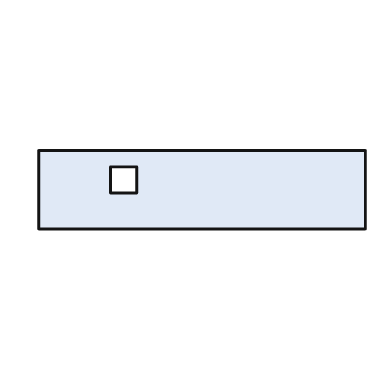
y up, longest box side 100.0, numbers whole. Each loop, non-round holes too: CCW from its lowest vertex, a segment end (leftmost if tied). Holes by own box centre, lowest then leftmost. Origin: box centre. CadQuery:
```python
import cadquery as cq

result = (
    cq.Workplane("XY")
    .moveTo(-50.0, -12.0)
    .lineTo(50.0, -12.0)
    .lineTo(50.0, 12.0)
    .lineTo(-50.0, 12.0)
    .close()
    .moveTo(-28.0, -1.0)
    .lineTo(-20.0, -1.0)
    .lineTo(-20.0, 7.0)
    .lineTo(-28.0, 7.0)
    .close()
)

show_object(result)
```